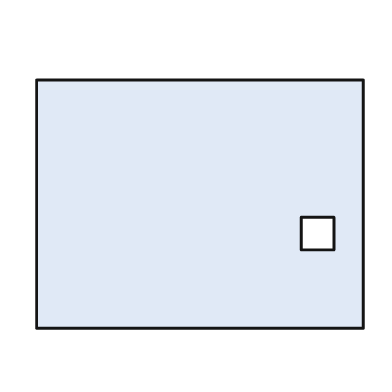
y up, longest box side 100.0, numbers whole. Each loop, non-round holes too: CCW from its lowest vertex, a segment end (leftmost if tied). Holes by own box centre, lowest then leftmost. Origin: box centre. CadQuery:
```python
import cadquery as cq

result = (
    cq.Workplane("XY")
    .moveTo(-50.0, -38.0)
    .lineTo(50.0, -38.0)
    .lineTo(50.0, 38.0)
    .lineTo(-50.0, 38.0)
    .close()
    .moveTo(31.0, -14.0)
    .lineTo(41.0, -14.0)
    .lineTo(41.0, -4.0)
    .lineTo(31.0, -4.0)
    .close()
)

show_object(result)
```